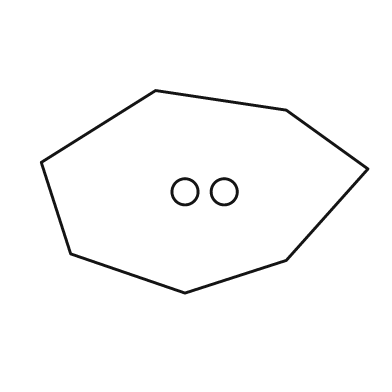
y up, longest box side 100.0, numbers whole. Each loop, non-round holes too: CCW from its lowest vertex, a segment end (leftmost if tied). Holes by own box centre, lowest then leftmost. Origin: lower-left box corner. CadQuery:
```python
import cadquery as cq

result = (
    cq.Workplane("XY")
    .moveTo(44.0, 0.0)
    .lineTo(75.0, 10.0)
    .lineTo(100.0, 38.0)
    .lineTo(75.0, 56.0)
    .lineTo(35.0, 62.0)
    .lineTo(0.0, 40.0)
    .lineTo(9.0, 12.0)
    .close()
    .moveTo(44.0, 31.0)
    .circle(4.0)
    .moveTo(56.0, 31.0)
    .circle(4.0)
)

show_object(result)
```